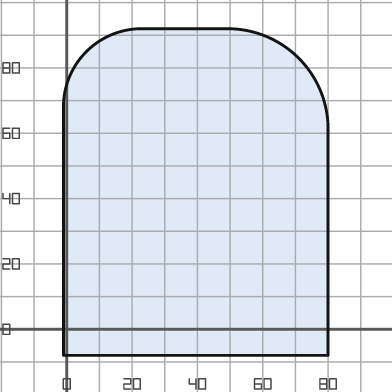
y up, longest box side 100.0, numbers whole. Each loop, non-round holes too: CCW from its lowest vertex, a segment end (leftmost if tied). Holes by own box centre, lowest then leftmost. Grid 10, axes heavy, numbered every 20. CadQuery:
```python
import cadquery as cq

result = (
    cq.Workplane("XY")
    .moveTo(-1.0, -8.0)
    .lineTo(80.0, -8.0)
    .lineTo(80.0, 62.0)
    .threePointArc((71.0, 83.0), (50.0, 92.0))
    .lineTo(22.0, 92.0)
    .threePointArc((6.0, 85.0), (-1.0, 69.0))
    .close()
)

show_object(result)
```